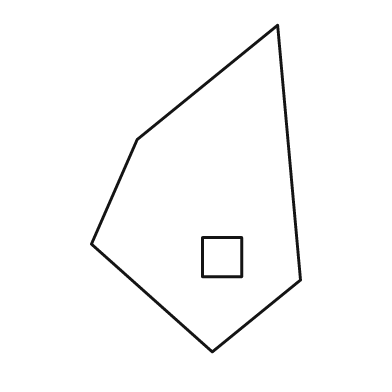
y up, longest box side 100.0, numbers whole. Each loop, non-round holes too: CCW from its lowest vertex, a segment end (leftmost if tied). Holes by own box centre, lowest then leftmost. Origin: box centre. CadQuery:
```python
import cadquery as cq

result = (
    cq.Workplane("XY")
    .moveTo(5.0, -50.0)
    .lineTo(32.0, -28.0)
    .lineTo(25.0, 50.0)
    .lineTo(-18.0, 15.0)
    .lineTo(-32.0, -17.0)
    .close()
    .moveTo(2.0, -27.0)
    .lineTo(14.0, -27.0)
    .lineTo(14.0, -15.0)
    .lineTo(2.0, -15.0)
    .close()
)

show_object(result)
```